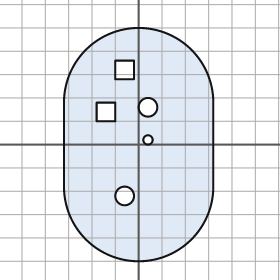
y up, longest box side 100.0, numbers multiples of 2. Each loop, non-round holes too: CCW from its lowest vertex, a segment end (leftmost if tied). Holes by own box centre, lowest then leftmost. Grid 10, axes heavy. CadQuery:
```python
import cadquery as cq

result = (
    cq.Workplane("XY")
    .moveTo(-32.0, -18.0)
    .threePointArc((0.0, -50.0), (32.0, -18.0))
    .lineTo(32.0, 18.0)
    .threePointArc((0.0, 50.0), (-32.0, 18.0))
    .close()
    .moveTo(-6.0, -22.0)
    .circle(4.0)
    .moveTo(4.0, 2.0)
    .circle(2.0)
    .moveTo(-18.0, 10.0)
    .lineTo(-10.0, 10.0)
    .lineTo(-10.0, 18.0)
    .lineTo(-18.0, 18.0)
    .close()
    .moveTo(4.0, 16.0)
    .circle(4.0)
    .moveTo(-10.0, 28.0)
    .lineTo(-2.0, 28.0)
    .lineTo(-2.0, 36.0)
    .lineTo(-10.0, 36.0)
    .close()
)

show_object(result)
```